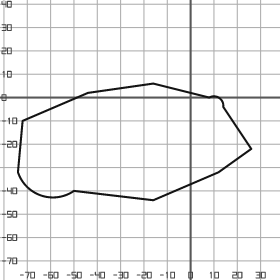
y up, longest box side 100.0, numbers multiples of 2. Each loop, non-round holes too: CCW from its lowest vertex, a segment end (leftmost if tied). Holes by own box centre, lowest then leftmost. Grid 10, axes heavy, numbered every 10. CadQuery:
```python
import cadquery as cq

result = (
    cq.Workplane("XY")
    .moveTo(-16.0, -44.0)
    .lineTo(12.0, -32.0)
    .lineTo(26.0, -22.0)
    .lineTo(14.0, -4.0)
    .threePointArc((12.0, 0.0), (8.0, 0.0))
    .lineTo(-16.0, 6.0)
    .lineTo(-44.0, 2.0)
    .lineTo(-72.0, -10.0)
    .lineTo(-74.0, -32.0)
    .threePointArc((-64.0, -42.0), (-50.0, -40.0))
    .close()
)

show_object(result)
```